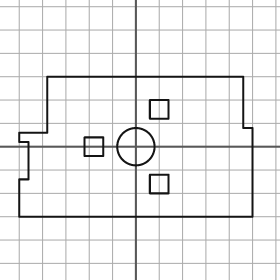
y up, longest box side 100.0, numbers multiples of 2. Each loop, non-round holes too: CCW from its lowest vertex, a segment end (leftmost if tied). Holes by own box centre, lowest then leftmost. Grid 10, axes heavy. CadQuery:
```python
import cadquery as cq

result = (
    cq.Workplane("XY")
    .moveTo(-50.0, -30.0)
    .lineTo(50.0, -30.0)
    .lineTo(50.0, 8.0)
    .lineTo(46.0, 8.0)
    .lineTo(46.0, 30.0)
    .lineTo(-38.0, 30.0)
    .lineTo(-38.0, 6.0)
    .lineTo(-50.0, 6.0)
    .lineTo(-50.0, 2.0)
    .lineTo(-46.0, 2.0)
    .lineTo(-46.0, -14.0)
    .lineTo(-50.0, -14.0)
    .close()
    .moveTo(6.0, -20.0)
    .lineTo(14.0, -20.0)
    .lineTo(14.0, -12.0)
    .lineTo(6.0, -12.0)
    .close()
    .moveTo(-22.0, -4.0)
    .lineTo(-14.0, -4.0)
    .lineTo(-14.0, 4.0)
    .lineTo(-22.0, 4.0)
    .close()
    .moveTo(0.0, 0.0)
    .circle(8.0)
    .moveTo(6.0, 12.0)
    .lineTo(14.0, 12.0)
    .lineTo(14.0, 20.0)
    .lineTo(6.0, 20.0)
    .close()
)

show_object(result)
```